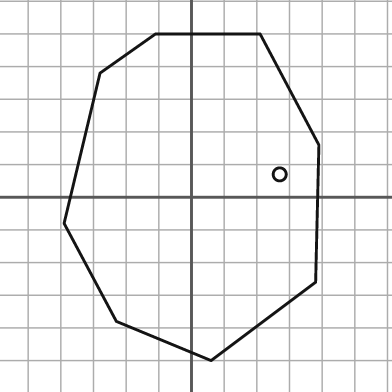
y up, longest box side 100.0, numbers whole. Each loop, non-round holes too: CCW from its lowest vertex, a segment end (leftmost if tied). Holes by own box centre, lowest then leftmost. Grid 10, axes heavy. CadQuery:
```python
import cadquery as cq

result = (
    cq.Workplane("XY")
    .moveTo(6.0, -50.0)
    .lineTo(38.0, -26.0)
    .lineTo(39.0, 16.0)
    .lineTo(21.0, 50.0)
    .lineTo(-11.0, 50.0)
    .lineTo(-28.0, 38.0)
    .lineTo(-39.0, -8.0)
    .lineTo(-23.0, -38.0)
    .close()
    .moveTo(27.0, 7.0)
    .circle(2.0)
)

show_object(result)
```